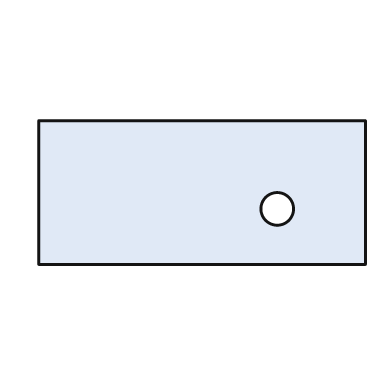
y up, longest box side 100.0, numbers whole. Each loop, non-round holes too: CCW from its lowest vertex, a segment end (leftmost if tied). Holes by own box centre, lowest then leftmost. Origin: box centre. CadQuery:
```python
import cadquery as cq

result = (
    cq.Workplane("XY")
    .moveTo(-50.0, -22.0)
    .lineTo(50.0, -22.0)
    .lineTo(50.0, 22.0)
    .lineTo(-50.0, 22.0)
    .close()
    .moveTo(23.0, -5.0)
    .circle(5.0)
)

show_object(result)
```